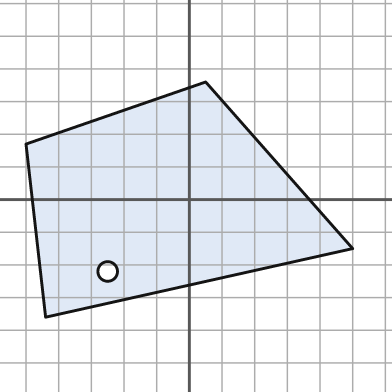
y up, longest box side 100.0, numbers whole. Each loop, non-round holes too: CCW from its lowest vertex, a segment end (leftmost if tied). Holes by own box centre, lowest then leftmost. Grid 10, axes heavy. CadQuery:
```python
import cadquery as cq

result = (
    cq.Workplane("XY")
    .moveTo(-44.0, -36.0)
    .lineTo(50.0, -15.0)
    .lineTo(5.0, 36.0)
    .lineTo(-50.0, 17.0)
    .close()
    .moveTo(-25.0, -22.0)
    .circle(3.0)
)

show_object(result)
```